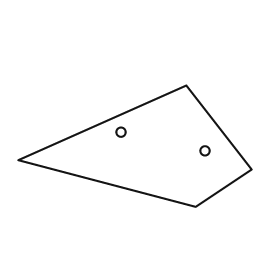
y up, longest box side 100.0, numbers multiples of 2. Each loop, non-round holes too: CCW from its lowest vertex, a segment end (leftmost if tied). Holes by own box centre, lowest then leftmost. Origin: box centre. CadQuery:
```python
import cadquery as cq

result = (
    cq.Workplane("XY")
    .moveTo(26.0, -26.0)
    .lineTo(50.0, -10.0)
    .lineTo(22.0, 26.0)
    .lineTo(-50.0, -6.0)
    .close()
    .moveTo(30.0, -2.0)
    .circle(2.0)
    .moveTo(-6.0, 6.0)
    .circle(2.0)
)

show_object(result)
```